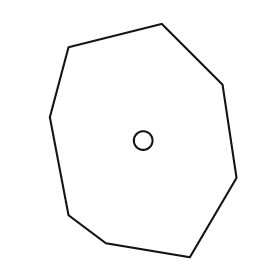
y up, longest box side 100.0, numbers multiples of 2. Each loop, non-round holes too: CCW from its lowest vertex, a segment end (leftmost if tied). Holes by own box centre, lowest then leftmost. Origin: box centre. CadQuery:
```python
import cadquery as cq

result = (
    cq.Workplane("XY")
    .moveTo(20.0, -50.0)
    .lineTo(40.0, -16.0)
    .lineTo(34.0, 24.0)
    .lineTo(8.0, 50.0)
    .lineTo(-32.0, 40.0)
    .lineTo(-40.0, 10.0)
    .lineTo(-32.0, -32.0)
    .lineTo(-16.0, -44.0)
    .close()
    .moveTo(0.0, 0.0)
    .circle(4.0)
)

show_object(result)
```